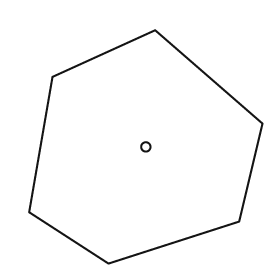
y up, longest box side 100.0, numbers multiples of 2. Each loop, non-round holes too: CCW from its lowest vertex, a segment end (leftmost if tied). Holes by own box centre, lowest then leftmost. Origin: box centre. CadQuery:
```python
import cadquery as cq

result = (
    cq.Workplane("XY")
    .moveTo(-16.0, -50.0)
    .lineTo(40.0, -32.0)
    .lineTo(50.0, 10.0)
    .lineTo(4.0, 50.0)
    .lineTo(-40.0, 30.0)
    .lineTo(-50.0, -28.0)
    .close()
    .moveTo(0.0, 0.0)
    .circle(2.0)
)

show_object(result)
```